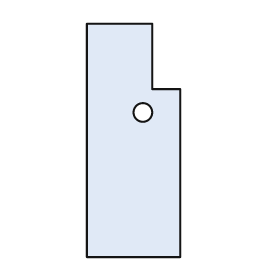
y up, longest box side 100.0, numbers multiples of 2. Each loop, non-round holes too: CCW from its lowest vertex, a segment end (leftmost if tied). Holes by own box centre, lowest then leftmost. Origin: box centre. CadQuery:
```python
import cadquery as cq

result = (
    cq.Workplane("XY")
    .moveTo(-20.0, -50.0)
    .lineTo(20.0, -50.0)
    .lineTo(20.0, 22.0)
    .lineTo(8.0, 22.0)
    .lineTo(8.0, 50.0)
    .lineTo(-20.0, 50.0)
    .close()
    .moveTo(4.0, 12.0)
    .circle(4.0)
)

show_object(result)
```